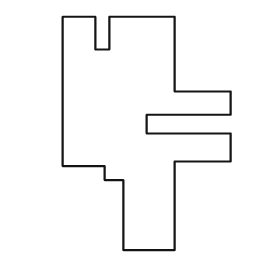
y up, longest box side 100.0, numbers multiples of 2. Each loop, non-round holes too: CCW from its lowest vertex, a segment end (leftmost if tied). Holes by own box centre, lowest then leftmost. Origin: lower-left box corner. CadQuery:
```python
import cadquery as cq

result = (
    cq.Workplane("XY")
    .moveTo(26.0, 0.0)
    .lineTo(48.0, 0.0)
    .lineTo(48.0, 38.0)
    .lineTo(72.0, 38.0)
    .lineTo(72.0, 50.0)
    .lineTo(36.0, 50.0)
    .lineTo(36.0, 58.0)
    .lineTo(72.0, 58.0)
    .lineTo(72.0, 68.0)
    .lineTo(48.0, 68.0)
    .lineTo(48.0, 100.0)
    .lineTo(20.0, 100.0)
    .lineTo(20.0, 86.0)
    .lineTo(14.0, 86.0)
    .lineTo(14.0, 100.0)
    .lineTo(0.0, 100.0)
    .lineTo(0.0, 36.0)
    .lineTo(18.0, 36.0)
    .lineTo(18.0, 30.0)
    .lineTo(26.0, 30.0)
    .close()
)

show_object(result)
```